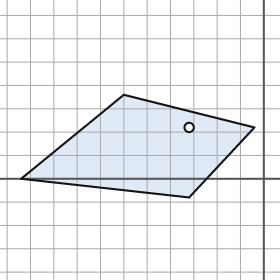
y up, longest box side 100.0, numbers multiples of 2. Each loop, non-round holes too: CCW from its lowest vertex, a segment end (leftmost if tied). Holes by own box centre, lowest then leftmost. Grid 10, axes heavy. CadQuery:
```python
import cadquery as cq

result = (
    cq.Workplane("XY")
    .moveTo(-32.0, -8.0)
    .lineTo(-4.0, 22.0)
    .lineTo(-60.0, 36.0)
    .lineTo(-104.0, 0.0)
    .close()
    .moveTo(-32.0, 22.0)
    .circle(2.0)
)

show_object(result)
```